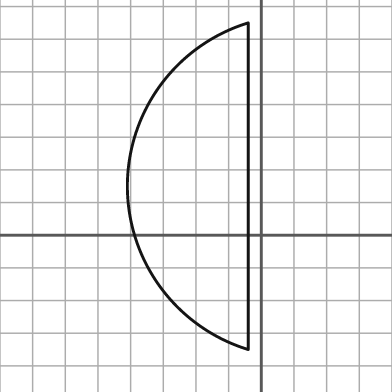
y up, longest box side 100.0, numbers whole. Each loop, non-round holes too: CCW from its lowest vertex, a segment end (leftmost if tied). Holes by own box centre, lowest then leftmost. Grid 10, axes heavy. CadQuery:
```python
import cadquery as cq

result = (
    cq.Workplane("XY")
    .moveTo(-4.0, -35.0)
    .lineTo(-4.0, 65.0)
    .threePointArc((-41.0, 15.0), (-4.0, -35.0))
    .close()
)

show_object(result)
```